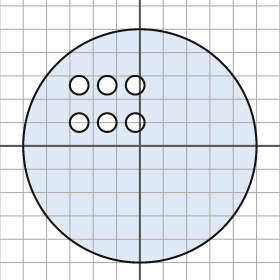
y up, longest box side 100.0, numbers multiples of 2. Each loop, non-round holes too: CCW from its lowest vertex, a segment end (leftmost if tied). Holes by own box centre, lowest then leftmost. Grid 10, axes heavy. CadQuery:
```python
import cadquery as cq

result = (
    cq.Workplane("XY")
    .moveTo(0.0, 0.0)
    .circle(50.0)
    .moveTo(-26.0, 10.0)
    .circle(4.0)
    .moveTo(-14.0, 10.0)
    .circle(4.0)
    .moveTo(-2.0, 10.0)
    .circle(4.0)
    .moveTo(-26.0, 26.0)
    .circle(4.0)
    .moveTo(-14.0, 26.0)
    .circle(4.0)
    .moveTo(-2.0, 26.0)
    .circle(4.0)
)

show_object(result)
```